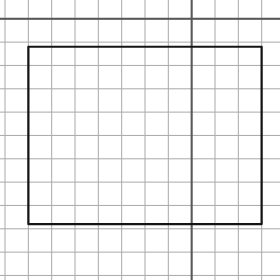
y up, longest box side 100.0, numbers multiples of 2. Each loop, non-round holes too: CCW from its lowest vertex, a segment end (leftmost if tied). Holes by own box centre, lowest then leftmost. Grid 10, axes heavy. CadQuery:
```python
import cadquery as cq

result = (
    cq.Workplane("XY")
    .moveTo(-70.0, -88.0)
    .lineTo(30.0, -88.0)
    .lineTo(30.0, -12.0)
    .lineTo(-70.0, -12.0)
    .close()
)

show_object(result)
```